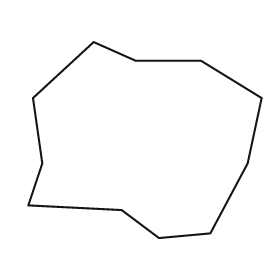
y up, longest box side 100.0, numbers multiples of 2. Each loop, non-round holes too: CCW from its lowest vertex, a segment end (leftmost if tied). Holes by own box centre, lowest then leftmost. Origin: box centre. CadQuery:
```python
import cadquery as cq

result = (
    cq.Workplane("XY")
    .moveTo(6.0, -42.0)
    .lineTo(28.0, -40.0)
    .lineTo(44.0, -10.0)
    .lineTo(50.0, 18.0)
    .lineTo(24.0, 34.0)
    .lineTo(-4.0, 34.0)
    .lineTo(-22.0, 42.0)
    .lineTo(-48.0, 18.0)
    .lineTo(-44.0, -10.0)
    .lineTo(-50.0, -28.0)
    .lineTo(-10.0, -30.0)
    .close()
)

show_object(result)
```